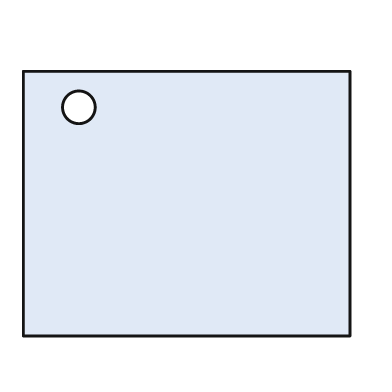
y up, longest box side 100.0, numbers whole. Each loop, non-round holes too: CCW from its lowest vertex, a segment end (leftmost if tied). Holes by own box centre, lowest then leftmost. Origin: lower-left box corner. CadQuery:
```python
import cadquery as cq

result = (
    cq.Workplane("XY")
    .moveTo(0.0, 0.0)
    .lineTo(100.0, 0.0)
    .lineTo(100.0, 81.0)
    .lineTo(0.0, 81.0)
    .close()
    .moveTo(17.0, 70.0)
    .circle(5.0)
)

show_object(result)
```